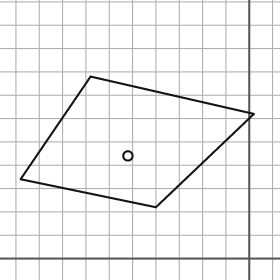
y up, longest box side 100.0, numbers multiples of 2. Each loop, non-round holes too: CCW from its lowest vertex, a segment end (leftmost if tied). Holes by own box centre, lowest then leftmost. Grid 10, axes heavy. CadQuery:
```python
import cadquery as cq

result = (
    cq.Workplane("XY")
    .moveTo(-40.0, 22.0)
    .lineTo(2.0, 62.0)
    .lineTo(-68.0, 78.0)
    .lineTo(-98.0, 34.0)
    .close()
    .moveTo(-52.0, 44.0)
    .circle(2.0)
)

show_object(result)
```